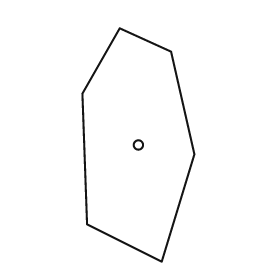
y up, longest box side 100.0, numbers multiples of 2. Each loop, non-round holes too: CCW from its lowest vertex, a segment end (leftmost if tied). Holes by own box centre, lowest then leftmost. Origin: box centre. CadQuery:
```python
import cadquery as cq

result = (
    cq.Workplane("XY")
    .moveTo(10.0, -50.0)
    .lineTo(24.0, -4.0)
    .lineTo(14.0, 40.0)
    .lineTo(-8.0, 50.0)
    .lineTo(-24.0, 22.0)
    .lineTo(-22.0, -34.0)
    .close()
    .moveTo(0.0, 0.0)
    .circle(2.0)
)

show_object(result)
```